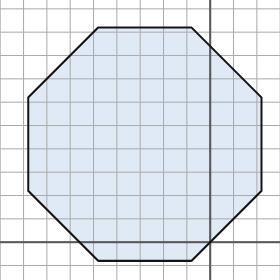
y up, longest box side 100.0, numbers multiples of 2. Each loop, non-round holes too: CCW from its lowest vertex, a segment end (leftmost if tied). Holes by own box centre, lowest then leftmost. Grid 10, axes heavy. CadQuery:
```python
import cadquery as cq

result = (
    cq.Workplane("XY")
    .moveTo(-48.0, -8.0)
    .lineTo(-8.0, -8.0)
    .lineTo(22.0, 22.0)
    .lineTo(22.0, 62.0)
    .lineTo(-8.0, 92.0)
    .lineTo(-48.0, 92.0)
    .lineTo(-78.0, 62.0)
    .lineTo(-78.0, 22.0)
    .close()
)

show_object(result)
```